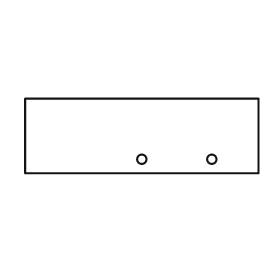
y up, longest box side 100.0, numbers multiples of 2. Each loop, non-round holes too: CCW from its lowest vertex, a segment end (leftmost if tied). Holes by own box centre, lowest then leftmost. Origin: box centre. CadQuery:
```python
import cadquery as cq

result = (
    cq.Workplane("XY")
    .moveTo(-50.0, -16.0)
    .lineTo(50.0, -16.0)
    .lineTo(50.0, 16.0)
    .lineTo(-50.0, 16.0)
    .close()
    .moveTo(0.0, -10.0)
    .circle(2.0)
    .moveTo(30.0, -10.0)
    .circle(2.0)
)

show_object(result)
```